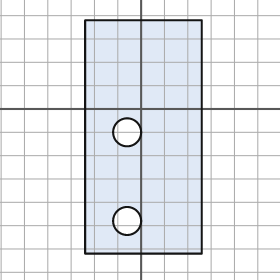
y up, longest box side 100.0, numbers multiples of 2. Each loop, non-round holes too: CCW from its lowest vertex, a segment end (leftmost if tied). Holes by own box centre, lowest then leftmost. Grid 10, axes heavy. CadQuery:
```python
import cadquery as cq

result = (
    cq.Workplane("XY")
    .moveTo(-24.0, -62.0)
    .lineTo(26.0, -62.0)
    .lineTo(26.0, 38.0)
    .lineTo(-24.0, 38.0)
    .close()
    .moveTo(-6.0, -48.0)
    .circle(6.0)
    .moveTo(-6.0, -10.0)
    .circle(6.0)
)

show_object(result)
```